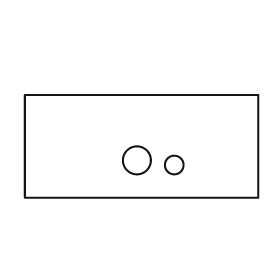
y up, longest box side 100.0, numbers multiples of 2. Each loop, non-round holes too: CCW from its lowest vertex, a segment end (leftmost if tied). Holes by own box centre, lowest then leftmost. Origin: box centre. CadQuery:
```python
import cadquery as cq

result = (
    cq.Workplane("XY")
    .moveTo(-50.0, -22.0)
    .lineTo(50.0, -22.0)
    .lineTo(50.0, 22.0)
    .lineTo(-50.0, 22.0)
    .close()
    .moveTo(14.0, -8.0)
    .circle(4.0)
    .moveTo(-2.0, -6.0)
    .circle(6.0)
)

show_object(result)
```